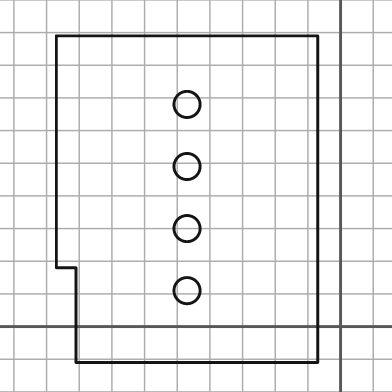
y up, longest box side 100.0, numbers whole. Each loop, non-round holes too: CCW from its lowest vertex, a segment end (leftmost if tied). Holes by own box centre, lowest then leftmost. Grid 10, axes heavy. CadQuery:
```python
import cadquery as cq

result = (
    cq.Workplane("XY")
    .moveTo(-81.0, -11.0)
    .lineTo(-7.0, -11.0)
    .lineTo(-7.0, 89.0)
    .lineTo(-87.0, 89.0)
    .lineTo(-87.0, 18.0)
    .lineTo(-81.0, 18.0)
    .close()
    .moveTo(-47.0, 11.0)
    .circle(4.0)
    .moveTo(-47.0, 30.0)
    .circle(4.0)
    .moveTo(-47.0, 49.0)
    .circle(4.0)
    .moveTo(-47.0, 68.0)
    .circle(4.0)
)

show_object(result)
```